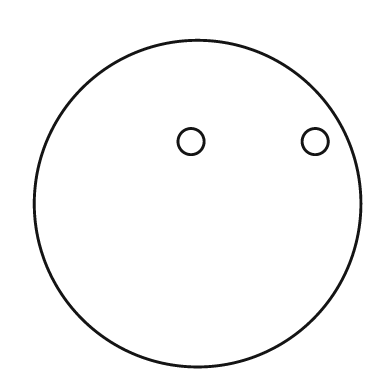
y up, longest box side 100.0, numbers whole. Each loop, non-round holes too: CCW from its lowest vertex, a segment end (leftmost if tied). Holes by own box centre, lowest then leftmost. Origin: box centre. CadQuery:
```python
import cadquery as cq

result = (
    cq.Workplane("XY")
    .moveTo(0.0, 0.0)
    .circle(50.0)
    .moveTo(-2.0, 19.0)
    .circle(4.0)
    .moveTo(36.0, 19.0)
    .circle(4.0)
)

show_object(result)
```